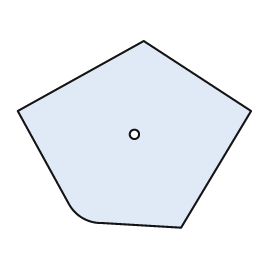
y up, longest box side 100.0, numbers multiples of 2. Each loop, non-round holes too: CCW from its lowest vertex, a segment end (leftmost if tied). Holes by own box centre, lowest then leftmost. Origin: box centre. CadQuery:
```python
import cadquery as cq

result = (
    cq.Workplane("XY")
    .moveTo(20.0, -40.0)
    .lineTo(50.0, 10.0)
    .lineTo(4.0, 40.0)
    .lineTo(-50.0, 10.0)
    .lineTo(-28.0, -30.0)
    .threePointArc((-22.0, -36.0), (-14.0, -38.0))
    .close()
    .moveTo(0.0, 0.0)
    .circle(2.0)
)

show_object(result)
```